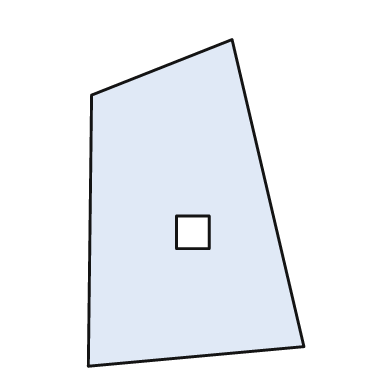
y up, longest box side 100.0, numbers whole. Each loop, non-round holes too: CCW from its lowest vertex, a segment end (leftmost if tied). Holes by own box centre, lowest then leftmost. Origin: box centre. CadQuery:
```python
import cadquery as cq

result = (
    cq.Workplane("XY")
    .moveTo(-33.0, -50.0)
    .lineTo(33.0, -44.0)
    .lineTo(11.0, 50.0)
    .lineTo(-32.0, 33.0)
    .close()
    .moveTo(-6.0, -14.0)
    .lineTo(4.0, -14.0)
    .lineTo(4.0, -4.0)
    .lineTo(-6.0, -4.0)
    .close()
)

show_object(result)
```